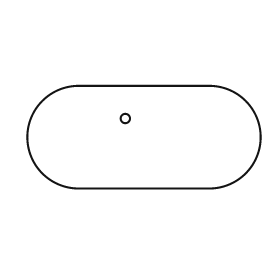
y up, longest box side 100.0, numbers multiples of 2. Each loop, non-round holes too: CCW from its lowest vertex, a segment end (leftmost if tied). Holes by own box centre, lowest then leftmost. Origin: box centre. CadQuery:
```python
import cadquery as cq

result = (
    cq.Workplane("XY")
    .moveTo(-28.0, -22.0)
    .lineTo(28.0, -22.0)
    .threePointArc((50.0, 0.0), (28.0, 22.0))
    .lineTo(-28.0, 22.0)
    .threePointArc((-50.0, 0.0), (-28.0, -22.0))
    .close()
    .moveTo(-8.0, 8.0)
    .circle(2.0)
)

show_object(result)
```